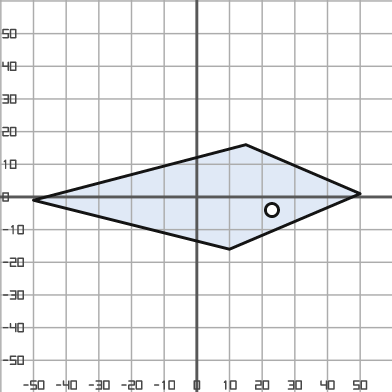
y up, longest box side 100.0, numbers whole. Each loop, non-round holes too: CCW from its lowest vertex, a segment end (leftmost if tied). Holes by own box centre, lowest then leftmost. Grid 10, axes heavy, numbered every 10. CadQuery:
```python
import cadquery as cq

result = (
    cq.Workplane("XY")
    .moveTo(10.0, -16.0)
    .lineTo(50.0, 1.0)
    .lineTo(15.0, 16.0)
    .lineTo(-50.0, -1.0)
    .close()
    .moveTo(23.0, -4.0)
    .circle(2.0)
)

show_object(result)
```